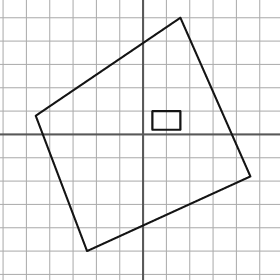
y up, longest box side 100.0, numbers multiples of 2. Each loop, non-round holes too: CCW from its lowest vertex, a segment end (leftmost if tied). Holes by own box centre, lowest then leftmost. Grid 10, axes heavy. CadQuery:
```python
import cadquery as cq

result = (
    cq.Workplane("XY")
    .moveTo(-24.0, -50.0)
    .lineTo(46.0, -18.0)
    .lineTo(16.0, 50.0)
    .lineTo(-46.0, 8.0)
    .close()
    .moveTo(4.0, 2.0)
    .lineTo(16.0, 2.0)
    .lineTo(16.0, 10.0)
    .lineTo(4.0, 10.0)
    .close()
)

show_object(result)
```